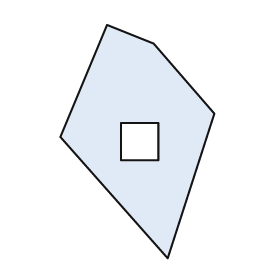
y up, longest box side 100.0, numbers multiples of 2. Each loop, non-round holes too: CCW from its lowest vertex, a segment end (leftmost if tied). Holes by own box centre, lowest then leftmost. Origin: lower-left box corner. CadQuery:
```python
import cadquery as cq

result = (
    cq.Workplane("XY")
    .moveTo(46.0, 0.0)
    .lineTo(66.0, 62.0)
    .lineTo(40.0, 92.0)
    .lineTo(20.0, 100.0)
    .lineTo(0.0, 52.0)
    .close()
    .moveTo(26.0, 42.0)
    .lineTo(42.0, 42.0)
    .lineTo(42.0, 58.0)
    .lineTo(26.0, 58.0)
    .close()
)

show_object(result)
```